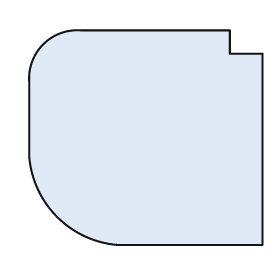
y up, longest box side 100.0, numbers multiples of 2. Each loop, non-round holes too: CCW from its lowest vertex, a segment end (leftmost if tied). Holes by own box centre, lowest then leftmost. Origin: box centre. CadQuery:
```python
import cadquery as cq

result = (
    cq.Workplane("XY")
    .moveTo(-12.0, -46.0)
    .lineTo(50.0, -46.0)
    .lineTo(50.0, 36.0)
    .lineTo(36.0, 36.0)
    .lineTo(36.0, 46.0)
    .lineTo(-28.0, 46.0)
    .threePointArc((-44.0, 40.0), (-50.0, 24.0))
    .lineTo(-50.0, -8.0)
    .threePointArc((-38.0, -34.0), (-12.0, -46.0))
    .close()
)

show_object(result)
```